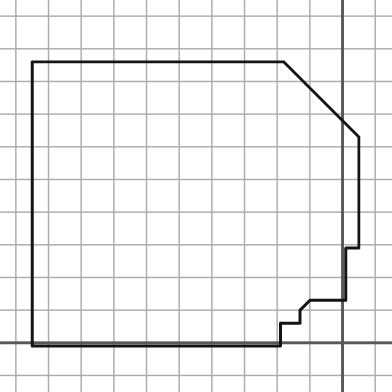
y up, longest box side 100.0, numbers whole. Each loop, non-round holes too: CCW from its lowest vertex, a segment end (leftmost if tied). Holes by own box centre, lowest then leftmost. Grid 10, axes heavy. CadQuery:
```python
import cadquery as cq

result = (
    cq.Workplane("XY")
    .moveTo(-95.0, -1.0)
    .lineTo(-19.0, -1.0)
    .lineTo(-19.0, 6.0)
    .lineTo(-13.0, 6.0)
    .lineTo(-13.0, 10.0)
    .lineTo(-10.0, 13.0)
    .lineTo(1.0, 13.0)
    .lineTo(1.0, 29.0)
    .lineTo(5.0, 29.0)
    .lineTo(5.0, 63.0)
    .lineTo(-18.0, 86.0)
    .lineTo(-95.0, 86.0)
    .close()
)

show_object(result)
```